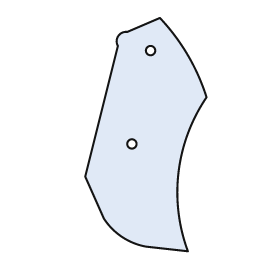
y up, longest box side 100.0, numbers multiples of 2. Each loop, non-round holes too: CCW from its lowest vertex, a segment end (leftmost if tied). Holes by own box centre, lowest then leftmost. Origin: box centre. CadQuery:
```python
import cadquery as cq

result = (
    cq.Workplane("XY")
    .moveTo(18.0, -50.0)
    .threePointArc((14.0, -16.0), (26.0, 16.0))
    .threePointArc((18.0, 34.0), (6.0, 50.0))
    .lineTo(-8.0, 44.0)
    .threePointArc((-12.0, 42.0), (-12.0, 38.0))
    .lineTo(-26.0, -18.0)
    .lineTo(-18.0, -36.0)
    .threePointArc((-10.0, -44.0), (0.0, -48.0))
    .close()
    .moveTo(-6.0, -4.0)
    .circle(2.0)
    .moveTo(2.0, 36.0)
    .circle(2.0)
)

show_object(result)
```